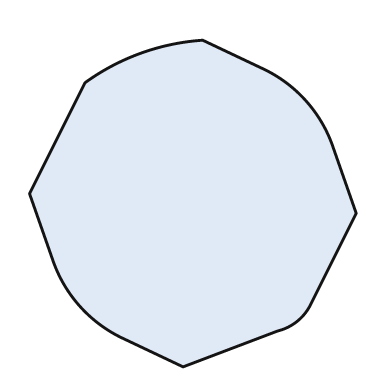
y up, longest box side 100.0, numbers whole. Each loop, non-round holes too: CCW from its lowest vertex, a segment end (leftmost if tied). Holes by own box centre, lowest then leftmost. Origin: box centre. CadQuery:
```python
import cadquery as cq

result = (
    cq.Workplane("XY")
    .moveTo(-3.0, -50.0)
    .lineTo(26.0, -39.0)
    .threePointArc((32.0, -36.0), (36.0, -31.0))
    .lineTo(50.0, -3.0)
    .lineTo(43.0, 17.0)
    .threePointArc((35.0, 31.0), (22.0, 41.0))
    .lineTo(3.0, 50.0)
    .threePointArc((-16.0, 46.0), (-33.0, 37.0))
    .lineTo(-50.0, 3.0)
    .lineTo(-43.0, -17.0)
    .threePointArc((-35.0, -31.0), (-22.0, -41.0))
    .close()
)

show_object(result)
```